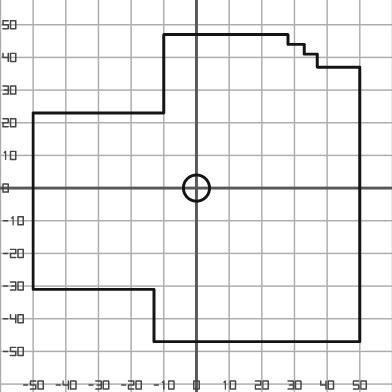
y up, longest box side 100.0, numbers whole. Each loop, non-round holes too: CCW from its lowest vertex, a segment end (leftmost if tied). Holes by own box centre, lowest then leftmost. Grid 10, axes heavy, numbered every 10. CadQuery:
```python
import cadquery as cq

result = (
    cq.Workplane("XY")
    .moveTo(-13.0, -47.0)
    .lineTo(50.0, -47.0)
    .lineTo(50.0, 37.0)
    .lineTo(37.0, 37.0)
    .lineTo(37.0, 41.0)
    .lineTo(33.0, 41.0)
    .lineTo(33.0, 44.0)
    .lineTo(28.0, 44.0)
    .lineTo(28.0, 47.0)
    .lineTo(-10.0, 47.0)
    .lineTo(-10.0, 23.0)
    .lineTo(-50.0, 23.0)
    .lineTo(-50.0, -31.0)
    .lineTo(-13.0, -31.0)
    .close()
    .moveTo(0.0, 0.0)
    .circle(4.0)
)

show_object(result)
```